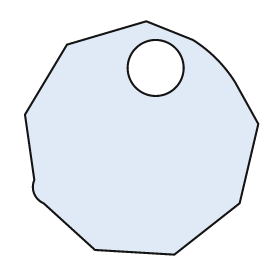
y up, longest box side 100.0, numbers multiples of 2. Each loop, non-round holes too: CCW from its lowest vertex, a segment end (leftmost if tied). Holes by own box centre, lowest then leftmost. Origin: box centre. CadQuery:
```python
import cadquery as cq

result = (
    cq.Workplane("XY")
    .moveTo(14.0, -50.0)
    .lineTo(42.0, -28.0)
    .lineTo(50.0, 6.0)
    .lineTo(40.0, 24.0)
    .threePointArc((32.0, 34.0), (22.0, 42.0))
    .lineTo(2.0, 50.0)
    .lineTo(-32.0, 40.0)
    .lineTo(-50.0, 10.0)
    .lineTo(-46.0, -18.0)
    .threePointArc((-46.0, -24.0), (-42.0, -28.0))
    .lineTo(-20.0, -48.0)
    .close()
    .moveTo(6.0, 30.0)
    .circle(12.0)
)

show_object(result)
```